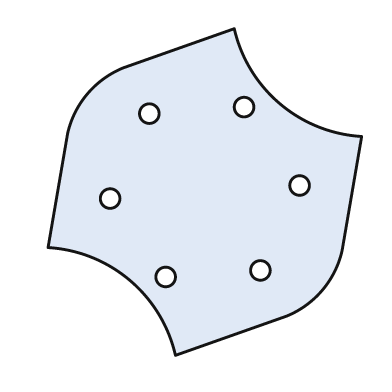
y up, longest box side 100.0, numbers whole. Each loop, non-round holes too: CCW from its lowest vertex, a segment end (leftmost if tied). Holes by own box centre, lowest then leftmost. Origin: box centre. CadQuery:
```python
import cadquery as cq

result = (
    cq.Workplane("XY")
    .moveTo(-9.0, -50.0)
    .lineTo(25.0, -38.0)
    .threePointArc((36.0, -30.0), (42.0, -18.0))
    .lineTo(48.0, 17.0)
    .threePointArc((23.0, 27.0), (9.0, 50.0))
    .lineTo(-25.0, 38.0)
    .threePointArc((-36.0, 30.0), (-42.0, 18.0))
    .lineTo(-48.0, -17.0)
    .threePointArc((-23.0, -27.0), (-9.0, -50.0))
    .close()
    .moveTo(-12.0, -26.0)
    .circle(3.0)
    .moveTo(17.0, -24.0)
    .circle(3.0)
    .moveTo(-29.0, -2.0)
    .circle(3.0)
    .moveTo(29.0, 2.0)
    .circle(3.0)
    .moveTo(-17.0, 24.0)
    .circle(3.0)
    .moveTo(12.0, 26.0)
    .circle(3.0)
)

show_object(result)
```